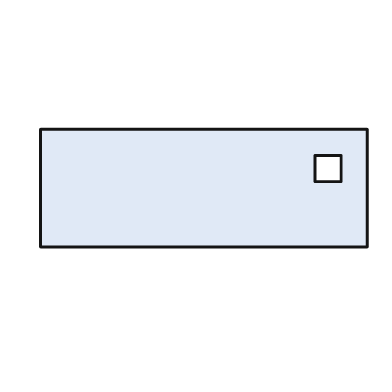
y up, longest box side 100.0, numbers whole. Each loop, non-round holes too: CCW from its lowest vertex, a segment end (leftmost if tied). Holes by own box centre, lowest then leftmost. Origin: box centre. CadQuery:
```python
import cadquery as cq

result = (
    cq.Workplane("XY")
    .moveTo(-50.0, -18.0)
    .lineTo(50.0, -18.0)
    .lineTo(50.0, 18.0)
    .lineTo(-50.0, 18.0)
    .close()
    .moveTo(34.0, 2.0)
    .lineTo(42.0, 2.0)
    .lineTo(42.0, 10.0)
    .lineTo(34.0, 10.0)
    .close()
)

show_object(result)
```